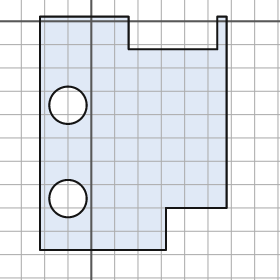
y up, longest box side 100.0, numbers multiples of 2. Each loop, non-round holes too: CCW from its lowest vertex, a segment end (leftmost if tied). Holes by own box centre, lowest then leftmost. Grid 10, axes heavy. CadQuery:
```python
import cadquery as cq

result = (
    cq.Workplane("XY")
    .moveTo(-22.0, -98.0)
    .lineTo(32.0, -98.0)
    .lineTo(32.0, -80.0)
    .lineTo(58.0, -80.0)
    .lineTo(58.0, 2.0)
    .lineTo(54.0, 2.0)
    .lineTo(54.0, -12.0)
    .lineTo(16.0, -12.0)
    .lineTo(16.0, 2.0)
    .lineTo(-22.0, 2.0)
    .close()
    .moveTo(-10.0, -76.0)
    .circle(8.0)
    .moveTo(-10.0, -36.0)
    .circle(8.0)
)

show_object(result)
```